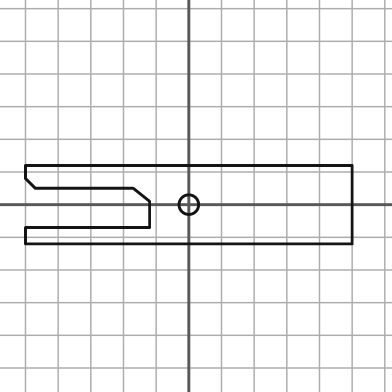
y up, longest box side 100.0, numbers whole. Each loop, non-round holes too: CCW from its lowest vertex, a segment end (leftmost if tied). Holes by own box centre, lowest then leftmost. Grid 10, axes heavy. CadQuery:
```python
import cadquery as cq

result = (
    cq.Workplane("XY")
    .moveTo(-50.0, -12.0)
    .lineTo(50.0, -12.0)
    .lineTo(50.0, 12.0)
    .lineTo(-50.0, 12.0)
    .lineTo(-50.0, 8.0)
    .lineTo(-47.0, 5.0)
    .lineTo(-17.0, 5.0)
    .lineTo(-12.0, 1.0)
    .lineTo(-12.0, -7.0)
    .lineTo(-50.0, -7.0)
    .close()
    .moveTo(0.0, 0.0)
    .circle(3.0)
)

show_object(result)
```